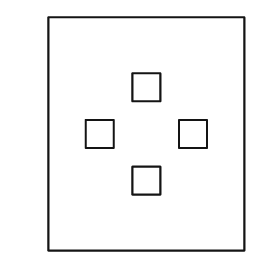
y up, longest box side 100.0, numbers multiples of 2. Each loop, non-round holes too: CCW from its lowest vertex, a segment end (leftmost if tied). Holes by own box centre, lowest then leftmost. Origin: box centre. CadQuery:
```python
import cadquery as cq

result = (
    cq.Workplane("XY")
    .moveTo(-42.0, -50.0)
    .lineTo(42.0, -50.0)
    .lineTo(42.0, 50.0)
    .lineTo(-42.0, 50.0)
    .close()
    .moveTo(-6.0, -26.0)
    .lineTo(6.0, -26.0)
    .lineTo(6.0, -14.0)
    .lineTo(-6.0, -14.0)
    .close()
    .moveTo(-26.0, -6.0)
    .lineTo(-14.0, -6.0)
    .lineTo(-14.0, 6.0)
    .lineTo(-26.0, 6.0)
    .close()
    .moveTo(14.0, -6.0)
    .lineTo(26.0, -6.0)
    .lineTo(26.0, 6.0)
    .lineTo(14.0, 6.0)
    .close()
    .moveTo(-6.0, 14.0)
    .lineTo(6.0, 14.0)
    .lineTo(6.0, 26.0)
    .lineTo(-6.0, 26.0)
    .close()
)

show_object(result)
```